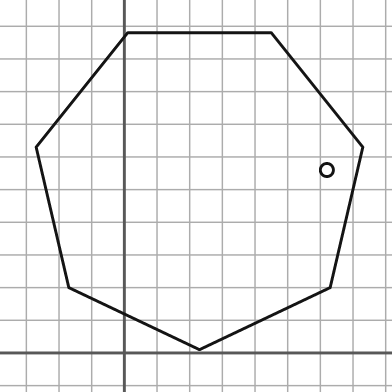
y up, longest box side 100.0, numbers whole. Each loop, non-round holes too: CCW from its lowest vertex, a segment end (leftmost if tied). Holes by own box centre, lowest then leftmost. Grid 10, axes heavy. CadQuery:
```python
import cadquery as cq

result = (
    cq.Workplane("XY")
    .moveTo(23.0, 1.0)
    .lineTo(63.0, 20.0)
    .lineTo(73.0, 63.0)
    .lineTo(45.0, 98.0)
    .lineTo(1.0, 98.0)
    .lineTo(-27.0, 63.0)
    .lineTo(-17.0, 20.0)
    .close()
    .moveTo(62.0, 56.0)
    .circle(2.0)
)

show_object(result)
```